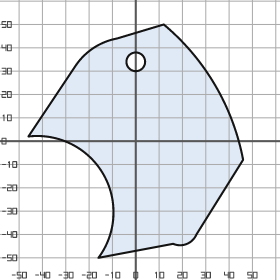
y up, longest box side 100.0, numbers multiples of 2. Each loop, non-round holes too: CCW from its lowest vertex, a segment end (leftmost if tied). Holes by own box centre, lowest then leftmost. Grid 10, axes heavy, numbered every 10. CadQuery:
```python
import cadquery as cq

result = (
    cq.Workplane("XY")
    .moveTo(-16.0, -50.0)
    .lineTo(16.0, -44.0)
    .threePointArc((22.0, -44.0), (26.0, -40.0))
    .lineTo(46.0, -8.0)
    .threePointArc((34.0, 24.0), (12.0, 50.0))
    .lineTo(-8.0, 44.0)
    .threePointArc((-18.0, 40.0), (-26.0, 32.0))
    .lineTo(-46.0, 2.0)
    .threePointArc((-14.0, -14.0), (-16.0, -50.0))
    .close()
    .moveTo(0.0, 34.0)
    .circle(4.0)
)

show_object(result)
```